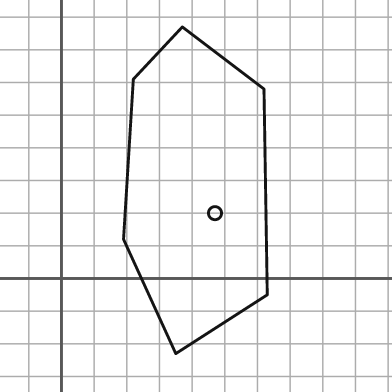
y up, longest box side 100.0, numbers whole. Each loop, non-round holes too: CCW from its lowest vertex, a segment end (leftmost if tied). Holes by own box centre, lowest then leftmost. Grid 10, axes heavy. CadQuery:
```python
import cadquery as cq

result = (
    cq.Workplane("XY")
    .moveTo(35.0, -23.0)
    .lineTo(63.0, -5.0)
    .lineTo(62.0, 58.0)
    .lineTo(37.0, 77.0)
    .lineTo(22.0, 61.0)
    .lineTo(19.0, 12.0)
    .close()
    .moveTo(47.0, 20.0)
    .circle(2.0)
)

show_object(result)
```